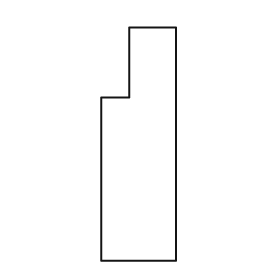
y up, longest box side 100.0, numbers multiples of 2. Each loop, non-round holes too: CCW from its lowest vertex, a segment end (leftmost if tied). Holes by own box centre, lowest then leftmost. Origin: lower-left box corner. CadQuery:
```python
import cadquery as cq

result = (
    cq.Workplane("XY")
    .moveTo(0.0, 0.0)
    .lineTo(32.0, 0.0)
    .lineTo(32.0, 100.0)
    .lineTo(12.0, 100.0)
    .lineTo(12.0, 70.0)
    .lineTo(0.0, 70.0)
    .close()
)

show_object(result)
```